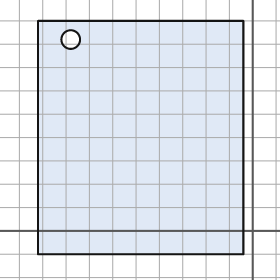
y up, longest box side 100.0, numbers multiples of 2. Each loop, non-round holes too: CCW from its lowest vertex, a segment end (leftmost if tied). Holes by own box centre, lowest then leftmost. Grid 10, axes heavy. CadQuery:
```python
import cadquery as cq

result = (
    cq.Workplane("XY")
    .moveTo(-92.0, -10.0)
    .lineTo(-4.0, -10.0)
    .lineTo(-4.0, 90.0)
    .lineTo(-92.0, 90.0)
    .close()
    .moveTo(-78.0, 82.0)
    .circle(4.0)
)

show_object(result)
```